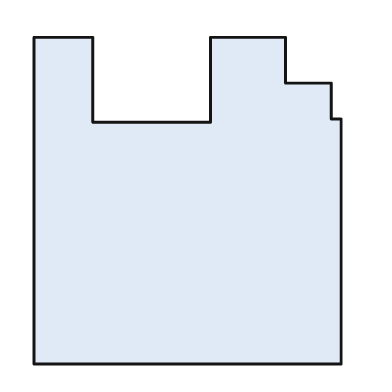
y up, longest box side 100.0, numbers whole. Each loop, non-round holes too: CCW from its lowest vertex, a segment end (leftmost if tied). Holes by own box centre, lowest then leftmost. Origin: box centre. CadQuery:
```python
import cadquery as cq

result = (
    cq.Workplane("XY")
    .moveTo(-47.0, -50.0)
    .lineTo(47.0, -50.0)
    .lineTo(47.0, 25.0)
    .lineTo(44.0, 25.0)
    .lineTo(44.0, 36.0)
    .lineTo(30.0, 36.0)
    .lineTo(30.0, 50.0)
    .lineTo(7.0, 50.0)
    .lineTo(7.0, 24.0)
    .lineTo(-29.0, 24.0)
    .lineTo(-29.0, 50.0)
    .lineTo(-47.0, 50.0)
    .close()
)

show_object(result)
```